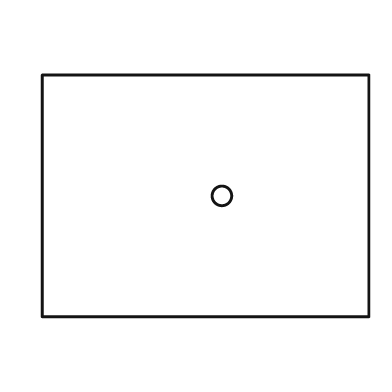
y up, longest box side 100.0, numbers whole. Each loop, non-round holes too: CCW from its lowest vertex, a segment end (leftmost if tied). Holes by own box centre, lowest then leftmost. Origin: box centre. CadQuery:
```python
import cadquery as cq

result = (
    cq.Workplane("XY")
    .moveTo(-50.0, -37.0)
    .lineTo(50.0, -37.0)
    .lineTo(50.0, 37.0)
    .lineTo(-50.0, 37.0)
    .close()
    .moveTo(5.0, 0.0)
    .circle(3.0)
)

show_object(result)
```